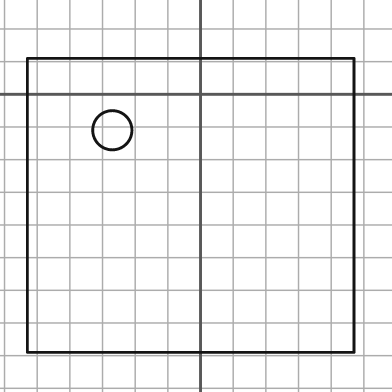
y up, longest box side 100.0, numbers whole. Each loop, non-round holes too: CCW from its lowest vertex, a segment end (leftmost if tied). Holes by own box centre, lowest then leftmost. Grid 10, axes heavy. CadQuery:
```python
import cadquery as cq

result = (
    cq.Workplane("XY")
    .moveTo(-53.0, -79.0)
    .lineTo(47.0, -79.0)
    .lineTo(47.0, 11.0)
    .lineTo(-53.0, 11.0)
    .close()
    .moveTo(-27.0, -11.0)
    .circle(6.0)
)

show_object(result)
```